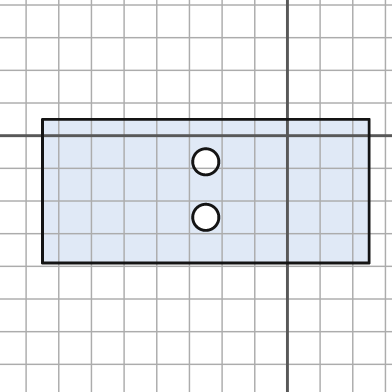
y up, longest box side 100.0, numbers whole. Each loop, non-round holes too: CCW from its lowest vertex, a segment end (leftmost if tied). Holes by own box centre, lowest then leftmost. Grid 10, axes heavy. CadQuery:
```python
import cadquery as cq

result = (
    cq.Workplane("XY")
    .moveTo(-75.0, -39.0)
    .lineTo(25.0, -39.0)
    .lineTo(25.0, 5.0)
    .lineTo(-75.0, 5.0)
    .close()
    .moveTo(-25.0, -25.0)
    .circle(4.0)
    .moveTo(-25.0, -8.0)
    .circle(4.0)
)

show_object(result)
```